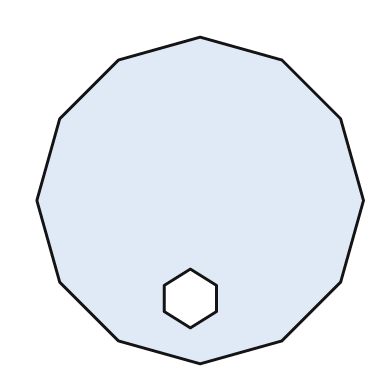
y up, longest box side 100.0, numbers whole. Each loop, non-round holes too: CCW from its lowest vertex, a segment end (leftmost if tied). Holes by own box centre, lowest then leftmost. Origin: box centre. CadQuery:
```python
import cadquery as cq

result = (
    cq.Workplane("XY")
    .moveTo(0.0, -50.0)
    .lineTo(25.0, -43.0)
    .lineTo(43.0, -25.0)
    .lineTo(50.0, 0.0)
    .lineTo(43.0, 25.0)
    .lineTo(25.0, 43.0)
    .lineTo(0.0, 50.0)
    .lineTo(-25.0, 43.0)
    .lineTo(-43.0, 25.0)
    .lineTo(-50.0, 0.0)
    .lineTo(-43.0, -25.0)
    .lineTo(-25.0, -43.0)
    .close()
    .moveTo(-3.0, -39.0)
    .lineTo(5.0, -34.0)
    .lineTo(5.0, -26.0)
    .lineTo(-3.0, -21.0)
    .lineTo(-11.0, -26.0)
    .lineTo(-11.0, -34.0)
    .close()
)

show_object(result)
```